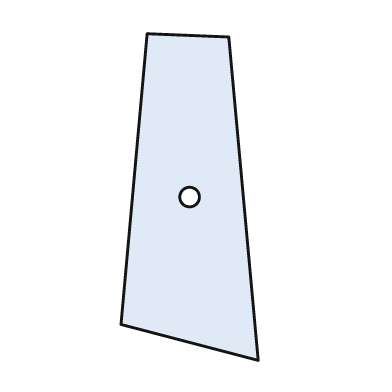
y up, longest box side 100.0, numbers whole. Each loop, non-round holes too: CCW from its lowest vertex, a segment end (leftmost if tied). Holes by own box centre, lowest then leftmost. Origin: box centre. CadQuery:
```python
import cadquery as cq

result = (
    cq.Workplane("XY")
    .moveTo(21.0, -50.0)
    .lineTo(12.0, 49.0)
    .lineTo(-13.0, 50.0)
    .lineTo(-21.0, -39.0)
    .close()
    .moveTo(0.0, 0.0)
    .circle(3.0)
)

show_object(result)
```